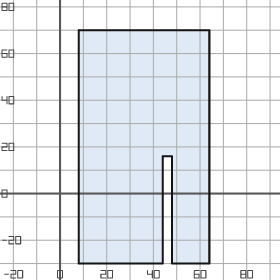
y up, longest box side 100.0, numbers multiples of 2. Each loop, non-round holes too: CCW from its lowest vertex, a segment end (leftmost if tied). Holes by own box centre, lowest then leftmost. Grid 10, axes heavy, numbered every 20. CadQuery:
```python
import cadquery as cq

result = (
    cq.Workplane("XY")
    .moveTo(8.0, -30.0)
    .lineTo(44.0, -30.0)
    .lineTo(44.0, 16.0)
    .lineTo(48.0, 16.0)
    .lineTo(48.0, -30.0)
    .lineTo(64.0, -30.0)
    .lineTo(64.0, 70.0)
    .lineTo(8.0, 70.0)
    .close()
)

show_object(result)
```